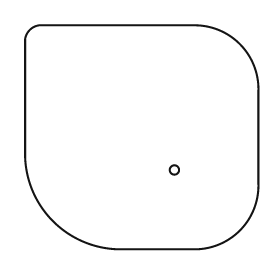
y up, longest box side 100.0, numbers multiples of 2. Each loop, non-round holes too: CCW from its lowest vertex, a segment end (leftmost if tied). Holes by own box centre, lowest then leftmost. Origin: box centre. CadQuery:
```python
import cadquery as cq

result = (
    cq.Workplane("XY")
    .moveTo(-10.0, -48.0)
    .lineTo(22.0, -48.0)
    .threePointArc((42.0, -40.0), (50.0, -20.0))
    .lineTo(50.0, 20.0)
    .threePointArc((42.0, 40.0), (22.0, 48.0))
    .lineTo(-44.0, 48.0)
    .threePointArc((-48.0, 46.0), (-50.0, 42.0))
    .lineTo(-50.0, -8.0)
    .threePointArc((-38.0, -36.0), (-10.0, -48.0))
    .close()
    .moveTo(14.0, -14.0)
    .circle(2.0)
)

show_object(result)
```